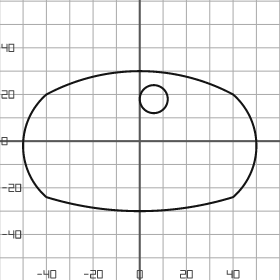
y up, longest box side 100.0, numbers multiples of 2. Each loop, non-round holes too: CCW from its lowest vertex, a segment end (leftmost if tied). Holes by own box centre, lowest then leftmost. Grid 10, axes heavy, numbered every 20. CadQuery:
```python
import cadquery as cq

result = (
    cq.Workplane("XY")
    .moveTo(-40.0, -24.0)
    .threePointArc((0.0, -30.0), (40.0, -24.0))
    .threePointArc((50.0, -2.0), (40.0, 20.0))
    .threePointArc((0.0, 30.0), (-40.0, 20.0))
    .threePointArc((-50.0, -2.0), (-40.0, -24.0))
    .close()
    .moveTo(6.0, 18.0)
    .circle(6.0)
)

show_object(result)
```